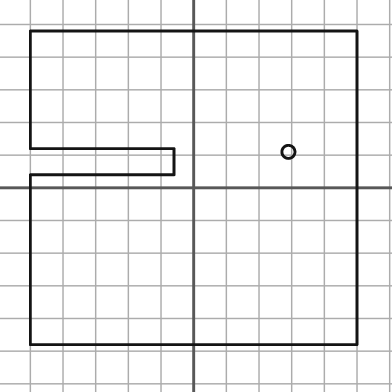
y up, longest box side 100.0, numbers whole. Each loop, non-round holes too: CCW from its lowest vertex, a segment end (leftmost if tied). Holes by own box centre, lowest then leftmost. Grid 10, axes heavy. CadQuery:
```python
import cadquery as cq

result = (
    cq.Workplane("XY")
    .moveTo(-50.0, -48.0)
    .lineTo(50.0, -48.0)
    .lineTo(50.0, 48.0)
    .lineTo(-50.0, 48.0)
    .lineTo(-50.0, 12.0)
    .lineTo(-6.0, 12.0)
    .lineTo(-6.0, 4.0)
    .lineTo(-50.0, 4.0)
    .close()
    .moveTo(29.0, 11.0)
    .circle(2.0)
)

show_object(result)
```